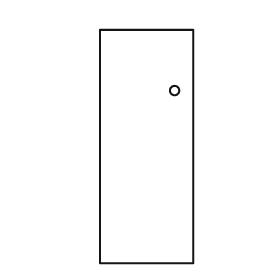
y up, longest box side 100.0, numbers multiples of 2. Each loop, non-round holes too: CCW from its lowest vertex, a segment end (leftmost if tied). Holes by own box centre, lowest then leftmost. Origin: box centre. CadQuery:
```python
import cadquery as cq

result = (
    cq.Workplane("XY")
    .moveTo(-20.0, -50.0)
    .lineTo(20.0, -50.0)
    .lineTo(20.0, 50.0)
    .lineTo(-20.0, 50.0)
    .close()
    .moveTo(12.0, 24.0)
    .circle(2.0)
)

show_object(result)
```